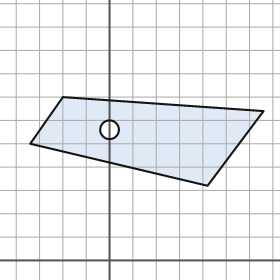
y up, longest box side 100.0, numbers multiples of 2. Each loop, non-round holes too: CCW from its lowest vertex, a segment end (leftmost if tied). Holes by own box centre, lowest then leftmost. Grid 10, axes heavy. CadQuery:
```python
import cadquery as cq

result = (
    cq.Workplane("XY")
    .moveTo(42.0, 32.0)
    .lineTo(66.0, 64.0)
    .lineTo(-20.0, 70.0)
    .lineTo(-34.0, 50.0)
    .close()
    .moveTo(0.0, 56.0)
    .circle(4.0)
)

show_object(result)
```